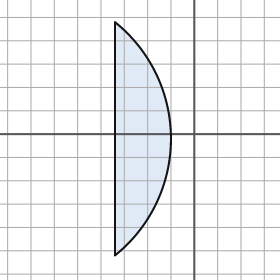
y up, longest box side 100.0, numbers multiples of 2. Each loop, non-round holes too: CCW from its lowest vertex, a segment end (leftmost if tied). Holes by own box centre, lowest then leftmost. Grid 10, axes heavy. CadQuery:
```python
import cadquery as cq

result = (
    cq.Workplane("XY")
    .moveTo(-34.0, -52.0)
    .threePointArc((-10.0, -2.0), (-34.0, 48.0))
    .close()
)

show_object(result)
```